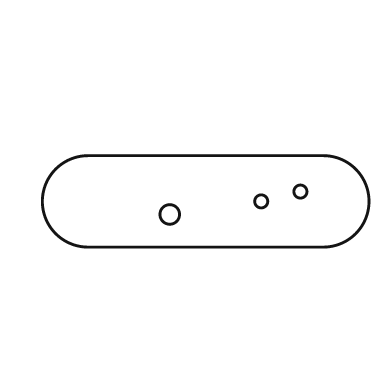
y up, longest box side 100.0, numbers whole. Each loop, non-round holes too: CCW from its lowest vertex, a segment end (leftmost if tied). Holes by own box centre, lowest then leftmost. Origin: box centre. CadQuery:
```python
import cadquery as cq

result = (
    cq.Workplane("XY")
    .moveTo(-36.0, -14.0)
    .lineTo(36.0, -14.0)
    .threePointArc((50.0, 0.0), (36.0, 14.0))
    .lineTo(-36.0, 14.0)
    .threePointArc((-50.0, 0.0), (-36.0, -14.0))
    .close()
    .moveTo(-11.0, -4.0)
    .circle(3.0)
    .moveTo(17.0, 0.0)
    .circle(2.0)
    .moveTo(29.0, 3.0)
    .circle(2.0)
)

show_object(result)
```